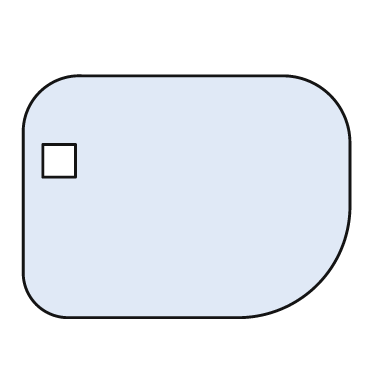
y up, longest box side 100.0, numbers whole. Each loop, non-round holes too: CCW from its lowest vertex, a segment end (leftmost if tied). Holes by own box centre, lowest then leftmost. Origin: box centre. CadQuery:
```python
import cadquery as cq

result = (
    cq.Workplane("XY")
    .moveTo(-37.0, -37.0)
    .lineTo(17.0, -37.0)
    .threePointArc((40.0, -27.0), (50.0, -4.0))
    .lineTo(50.0, 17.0)
    .threePointArc((44.0, 31.0), (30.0, 37.0))
    .lineTo(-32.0, 37.0)
    .threePointArc((-45.0, 32.0), (-50.0, 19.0))
    .lineTo(-50.0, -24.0)
    .threePointArc((-46.0, -33.0), (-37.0, -37.0))
    .close()
    .moveTo(-44.0, 6.0)
    .lineTo(-34.0, 6.0)
    .lineTo(-34.0, 16.0)
    .lineTo(-44.0, 16.0)
    .close()
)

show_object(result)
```